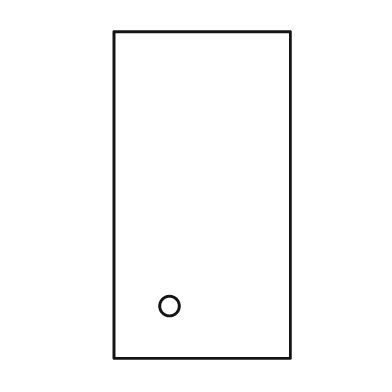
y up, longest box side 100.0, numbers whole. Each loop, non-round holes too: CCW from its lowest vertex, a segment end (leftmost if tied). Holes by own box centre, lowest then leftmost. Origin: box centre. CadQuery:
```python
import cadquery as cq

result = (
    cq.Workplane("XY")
    .moveTo(-27.0, -50.0)
    .lineTo(27.0, -50.0)
    .lineTo(27.0, 50.0)
    .lineTo(-27.0, 50.0)
    .close()
    .moveTo(-10.0, -34.0)
    .circle(3.0)
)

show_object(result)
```